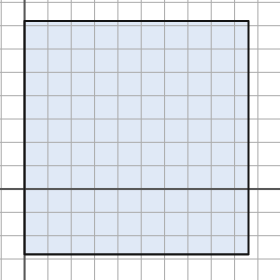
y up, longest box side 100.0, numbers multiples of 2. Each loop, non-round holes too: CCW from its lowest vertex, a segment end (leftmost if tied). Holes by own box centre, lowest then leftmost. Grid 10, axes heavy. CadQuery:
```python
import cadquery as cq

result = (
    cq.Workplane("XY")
    .moveTo(0.0, -28.0)
    .lineTo(96.0, -28.0)
    .lineTo(96.0, 72.0)
    .lineTo(0.0, 72.0)
    .close()
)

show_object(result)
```